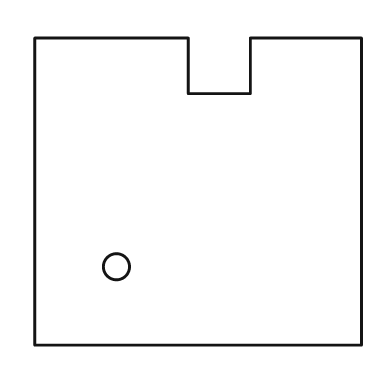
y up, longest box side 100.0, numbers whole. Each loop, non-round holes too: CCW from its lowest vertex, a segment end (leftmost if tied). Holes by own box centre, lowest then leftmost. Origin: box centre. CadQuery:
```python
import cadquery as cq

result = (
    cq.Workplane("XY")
    .moveTo(-50.0, -47.0)
    .lineTo(50.0, -47.0)
    .lineTo(50.0, 47.0)
    .lineTo(16.0, 47.0)
    .lineTo(16.0, 30.0)
    .lineTo(-3.0, 30.0)
    .lineTo(-3.0, 47.0)
    .lineTo(-50.0, 47.0)
    .close()
    .moveTo(-25.0, -23.0)
    .circle(4.0)
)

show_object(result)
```